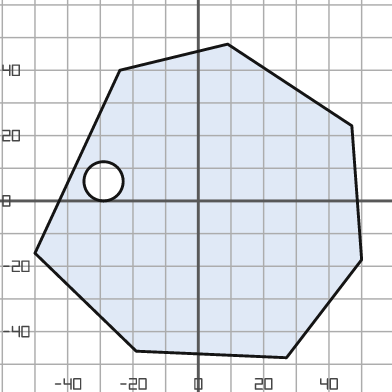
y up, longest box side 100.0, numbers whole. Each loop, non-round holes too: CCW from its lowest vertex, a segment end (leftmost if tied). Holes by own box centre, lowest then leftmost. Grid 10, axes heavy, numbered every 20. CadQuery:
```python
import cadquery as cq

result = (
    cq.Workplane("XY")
    .moveTo(27.0, -48.0)
    .lineTo(50.0, -18.0)
    .lineTo(47.0, 23.0)
    .lineTo(9.0, 48.0)
    .lineTo(-24.0, 40.0)
    .lineTo(-50.0, -16.0)
    .lineTo(-19.0, -46.0)
    .close()
    .moveTo(-29.0, 6.0)
    .circle(6.0)
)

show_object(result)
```